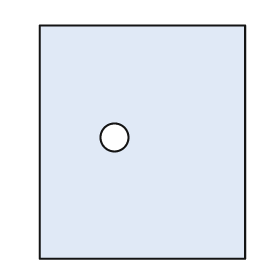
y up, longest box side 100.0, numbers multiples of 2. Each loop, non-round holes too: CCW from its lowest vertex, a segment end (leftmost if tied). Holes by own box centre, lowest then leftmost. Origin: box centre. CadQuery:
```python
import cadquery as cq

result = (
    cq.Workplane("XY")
    .moveTo(-44.0, -50.0)
    .lineTo(44.0, -50.0)
    .lineTo(44.0, 50.0)
    .lineTo(-44.0, 50.0)
    .close()
    .moveTo(-12.0, 2.0)
    .circle(6.0)
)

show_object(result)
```